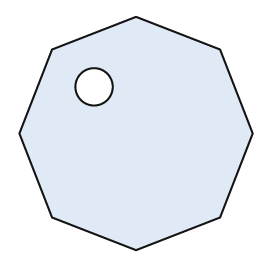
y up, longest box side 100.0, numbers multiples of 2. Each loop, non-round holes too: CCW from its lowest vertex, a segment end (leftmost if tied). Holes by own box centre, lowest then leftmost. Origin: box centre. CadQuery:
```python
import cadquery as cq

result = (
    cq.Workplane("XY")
    .moveTo(0.0, -50.0)
    .lineTo(36.0, -36.0)
    .lineTo(50.0, 0.0)
    .lineTo(36.0, 36.0)
    .lineTo(0.0, 50.0)
    .lineTo(-36.0, 36.0)
    .lineTo(-50.0, 0.0)
    .lineTo(-36.0, -36.0)
    .close()
    .moveTo(-18.0, 20.0)
    .circle(8.0)
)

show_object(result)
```